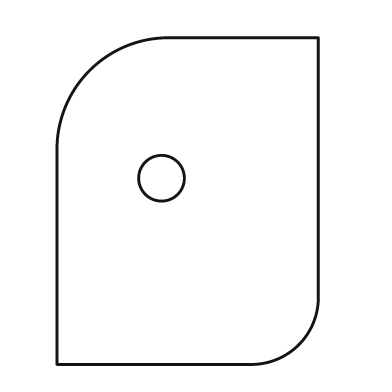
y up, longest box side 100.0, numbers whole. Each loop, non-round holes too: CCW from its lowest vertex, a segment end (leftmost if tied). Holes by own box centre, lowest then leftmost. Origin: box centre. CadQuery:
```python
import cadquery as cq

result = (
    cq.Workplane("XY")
    .moveTo(-40.0, -50.0)
    .lineTo(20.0, -50.0)
    .threePointArc((34.0, -44.0), (40.0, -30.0))
    .lineTo(40.0, 50.0)
    .lineTo(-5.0, 50.0)
    .threePointArc((-30.0, 40.0), (-40.0, 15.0))
    .close()
    .moveTo(-8.0, 7.0)
    .circle(7.0)
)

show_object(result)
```